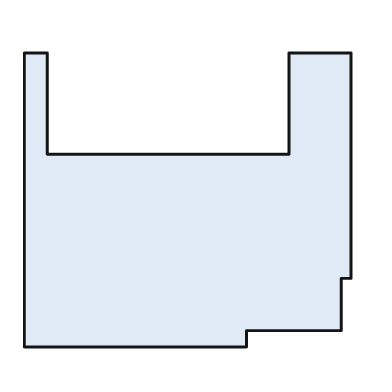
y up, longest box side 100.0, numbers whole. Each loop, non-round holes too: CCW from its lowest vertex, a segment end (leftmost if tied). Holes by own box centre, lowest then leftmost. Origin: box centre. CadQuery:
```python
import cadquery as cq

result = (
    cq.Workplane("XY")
    .moveTo(-50.0, -45.0)
    .lineTo(18.0, -45.0)
    .lineTo(18.0, -40.0)
    .lineTo(47.0, -40.0)
    .lineTo(47.0, -24.0)
    .lineTo(50.0, -24.0)
    .lineTo(50.0, 45.0)
    .lineTo(31.0, 45.0)
    .lineTo(31.0, 14.0)
    .lineTo(-43.0, 14.0)
    .lineTo(-43.0, 45.0)
    .lineTo(-50.0, 45.0)
    .close()
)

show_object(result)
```